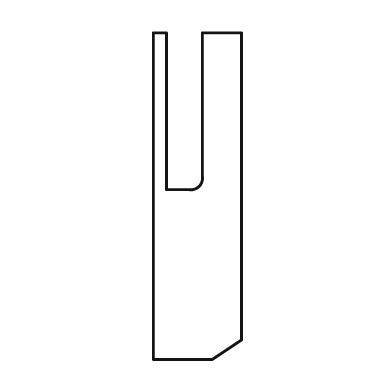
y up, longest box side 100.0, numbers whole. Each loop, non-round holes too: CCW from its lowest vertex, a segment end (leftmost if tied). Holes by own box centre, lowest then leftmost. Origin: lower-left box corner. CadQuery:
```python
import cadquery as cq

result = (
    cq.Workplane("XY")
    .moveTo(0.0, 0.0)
    .lineTo(18.0, 0.0)
    .lineTo(27.0, 6.0)
    .lineTo(27.0, 100.0)
    .lineTo(15.0, 100.0)
    .lineTo(15.0, 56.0)
    .threePointArc((14.0, 53.0), (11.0, 52.0))
    .lineTo(4.0, 52.0)
    .lineTo(4.0, 100.0)
    .lineTo(0.0, 100.0)
    .close()
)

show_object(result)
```